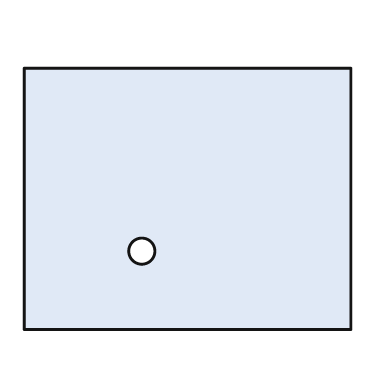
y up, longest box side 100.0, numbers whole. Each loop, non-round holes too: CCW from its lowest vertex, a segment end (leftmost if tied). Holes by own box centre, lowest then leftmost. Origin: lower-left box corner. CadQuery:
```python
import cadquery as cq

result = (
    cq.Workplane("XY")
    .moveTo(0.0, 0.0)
    .lineTo(100.0, 0.0)
    .lineTo(100.0, 80.0)
    .lineTo(0.0, 80.0)
    .close()
    .moveTo(36.0, 24.0)
    .circle(4.0)
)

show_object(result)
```